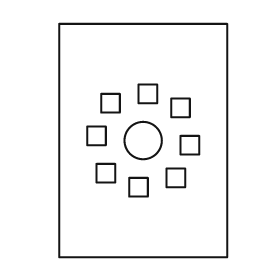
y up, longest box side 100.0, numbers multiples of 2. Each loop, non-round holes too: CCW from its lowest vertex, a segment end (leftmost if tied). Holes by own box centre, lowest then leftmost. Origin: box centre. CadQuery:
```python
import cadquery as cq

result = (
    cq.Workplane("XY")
    .moveTo(-36.0, -50.0)
    .lineTo(36.0, -50.0)
    .lineTo(36.0, 50.0)
    .lineTo(-36.0, 50.0)
    .close()
    .moveTo(-6.0, -24.0)
    .lineTo(2.0, -24.0)
    .lineTo(2.0, -16.0)
    .lineTo(-6.0, -16.0)
    .close()
    .moveTo(10.0, -20.0)
    .lineTo(18.0, -20.0)
    .lineTo(18.0, -12.0)
    .lineTo(10.0, -12.0)
    .close()
    .moveTo(-20.0, -18.0)
    .lineTo(-12.0, -18.0)
    .lineTo(-12.0, -10.0)
    .lineTo(-20.0, -10.0)
    .close()
    .moveTo(16.0, -6.0)
    .lineTo(24.0, -6.0)
    .lineTo(24.0, 2.0)
    .lineTo(16.0, 2.0)
    .close()
    .moveTo(0.0, 0.0)
    .circle(8.0)
    .moveTo(-24.0, -2.0)
    .lineTo(-16.0, -2.0)
    .lineTo(-16.0, 6.0)
    .lineTo(-24.0, 6.0)
    .close()
    .moveTo(12.0, 10.0)
    .lineTo(20.0, 10.0)
    .lineTo(20.0, 18.0)
    .lineTo(12.0, 18.0)
    .close()
    .moveTo(-18.0, 12.0)
    .lineTo(-10.0, 12.0)
    .lineTo(-10.0, 20.0)
    .lineTo(-18.0, 20.0)
    .close()
    .moveTo(-2.0, 16.0)
    .lineTo(6.0, 16.0)
    .lineTo(6.0, 24.0)
    .lineTo(-2.0, 24.0)
    .close()
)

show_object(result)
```